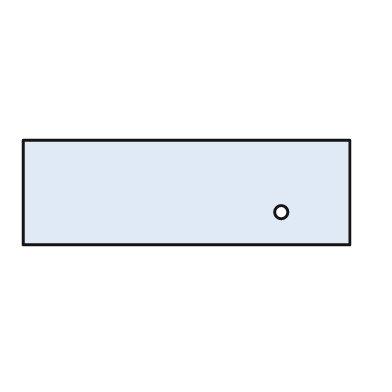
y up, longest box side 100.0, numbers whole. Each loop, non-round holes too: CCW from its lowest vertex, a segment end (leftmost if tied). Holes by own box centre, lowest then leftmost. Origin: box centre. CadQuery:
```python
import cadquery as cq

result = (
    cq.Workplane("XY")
    .moveTo(-50.0, -16.0)
    .lineTo(50.0, -16.0)
    .lineTo(50.0, 16.0)
    .lineTo(-50.0, 16.0)
    .close()
    .moveTo(29.0, -6.0)
    .circle(2.0)
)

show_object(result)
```